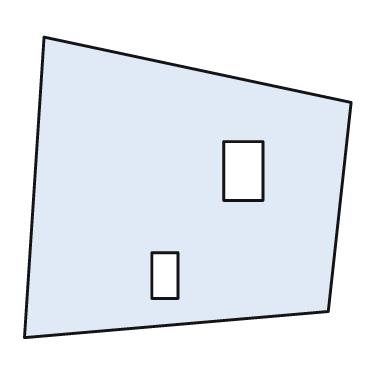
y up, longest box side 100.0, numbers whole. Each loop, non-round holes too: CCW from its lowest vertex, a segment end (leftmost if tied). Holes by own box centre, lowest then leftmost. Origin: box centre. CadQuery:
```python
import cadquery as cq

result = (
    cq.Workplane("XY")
    .moveTo(-50.0, -46.0)
    .lineTo(43.0, -38.0)
    .lineTo(50.0, 26.0)
    .lineTo(-44.0, 46.0)
    .close()
    .moveTo(-11.0, -34.0)
    .lineTo(-3.0, -34.0)
    .lineTo(-3.0, -20.0)
    .lineTo(-11.0, -20.0)
    .close()
    .moveTo(11.0, -4.0)
    .lineTo(23.0, -4.0)
    .lineTo(23.0, 14.0)
    .lineTo(11.0, 14.0)
    .close()
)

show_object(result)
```